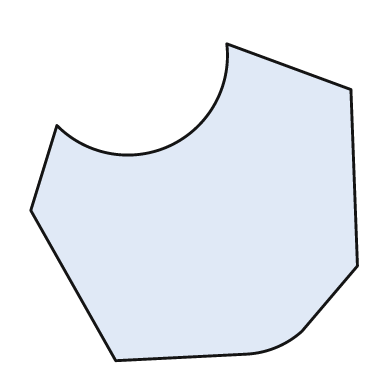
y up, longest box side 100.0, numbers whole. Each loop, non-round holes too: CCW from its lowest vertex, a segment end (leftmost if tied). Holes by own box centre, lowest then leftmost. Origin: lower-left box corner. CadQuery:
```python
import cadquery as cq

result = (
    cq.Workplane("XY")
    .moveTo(26.0, 0.0)
    .lineTo(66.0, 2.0)
    .threePointArc((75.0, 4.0), (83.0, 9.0))
    .lineTo(100.0, 29.0)
    .lineTo(98.0, 83.0)
    .lineTo(60.0, 97.0)
    .threePointArc((43.0, 66.0), (8.0, 72.0))
    .lineTo(0.0, 46.0)
    .close()
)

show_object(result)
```